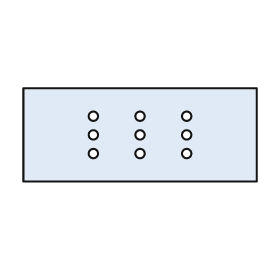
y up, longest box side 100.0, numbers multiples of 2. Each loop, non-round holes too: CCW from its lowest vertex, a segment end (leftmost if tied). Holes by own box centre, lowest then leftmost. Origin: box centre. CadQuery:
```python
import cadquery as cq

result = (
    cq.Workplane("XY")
    .moveTo(-50.0, -20.0)
    .lineTo(50.0, -20.0)
    .lineTo(50.0, 20.0)
    .lineTo(-50.0, 20.0)
    .close()
    .moveTo(-20.0, -8.0)
    .circle(2.0)
    .moveTo(0.0, -8.0)
    .circle(2.0)
    .moveTo(20.0, -8.0)
    .circle(2.0)
    .moveTo(-20.0, 0.0)
    .circle(2.0)
    .moveTo(0.0, 0.0)
    .circle(2.0)
    .moveTo(20.0, 0.0)
    .circle(2.0)
    .moveTo(-20.0, 8.0)
    .circle(2.0)
    .moveTo(0.0, 8.0)
    .circle(2.0)
    .moveTo(20.0, 8.0)
    .circle(2.0)
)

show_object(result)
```